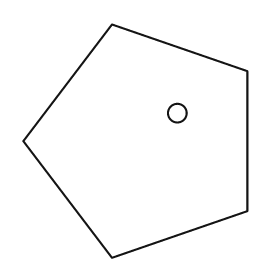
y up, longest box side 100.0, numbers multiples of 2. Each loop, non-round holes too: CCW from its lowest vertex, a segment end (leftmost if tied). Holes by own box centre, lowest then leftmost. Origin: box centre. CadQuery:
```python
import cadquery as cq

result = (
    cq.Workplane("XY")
    .moveTo(-10.0, -50.0)
    .lineTo(48.0, -30.0)
    .lineTo(48.0, 30.0)
    .lineTo(-10.0, 50.0)
    .lineTo(-48.0, 0.0)
    .close()
    .moveTo(18.0, 12.0)
    .circle(4.0)
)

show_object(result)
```